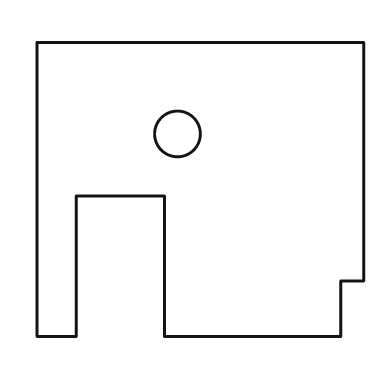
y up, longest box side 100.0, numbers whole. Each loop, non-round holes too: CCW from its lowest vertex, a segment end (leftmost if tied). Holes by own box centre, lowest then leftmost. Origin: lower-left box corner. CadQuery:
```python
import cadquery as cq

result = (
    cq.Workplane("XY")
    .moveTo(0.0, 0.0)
    .lineTo(12.0, 0.0)
    .lineTo(12.0, 43.0)
    .lineTo(39.0, 43.0)
    .lineTo(39.0, 0.0)
    .lineTo(93.0, 0.0)
    .lineTo(93.0, 17.0)
    .lineTo(100.0, 17.0)
    .lineTo(100.0, 90.0)
    .lineTo(0.0, 90.0)
    .close()
    .moveTo(43.0, 62.0)
    .circle(7.0)
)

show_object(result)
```